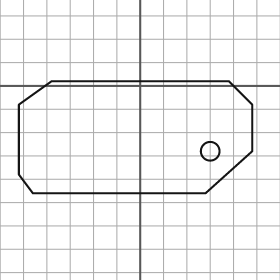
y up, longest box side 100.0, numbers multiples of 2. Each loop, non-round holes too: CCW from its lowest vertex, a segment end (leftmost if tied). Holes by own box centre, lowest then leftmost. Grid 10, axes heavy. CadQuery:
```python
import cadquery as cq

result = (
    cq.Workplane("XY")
    .moveTo(-46.0, -46.0)
    .lineTo(28.0, -46.0)
    .lineTo(48.0, -28.0)
    .lineTo(48.0, -8.0)
    .lineTo(38.0, 2.0)
    .lineTo(-38.0, 2.0)
    .lineTo(-52.0, -8.0)
    .lineTo(-52.0, -38.0)
    .close()
    .moveTo(30.0, -28.0)
    .circle(4.0)
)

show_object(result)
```